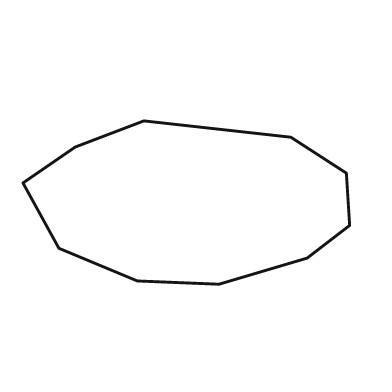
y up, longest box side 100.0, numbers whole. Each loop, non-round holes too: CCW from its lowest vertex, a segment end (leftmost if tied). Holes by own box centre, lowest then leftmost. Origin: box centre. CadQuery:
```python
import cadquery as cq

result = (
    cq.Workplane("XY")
    .moveTo(10.0, -25.0)
    .lineTo(37.0, -17.0)
    .lineTo(50.0, -7.0)
    .lineTo(49.0, 9.0)
    .lineTo(32.0, 20.0)
    .lineTo(-13.0, 25.0)
    .lineTo(-34.0, 17.0)
    .lineTo(-50.0, 6.0)
    .lineTo(-39.0, -14.0)
    .lineTo(-15.0, -24.0)
    .close()
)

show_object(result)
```